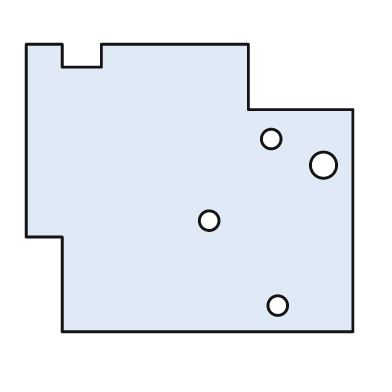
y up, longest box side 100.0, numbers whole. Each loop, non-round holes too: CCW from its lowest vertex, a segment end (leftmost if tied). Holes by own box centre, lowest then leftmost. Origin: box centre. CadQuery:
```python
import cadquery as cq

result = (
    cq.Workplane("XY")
    .moveTo(-39.0, -44.0)
    .lineTo(50.0, -44.0)
    .lineTo(50.0, 24.0)
    .lineTo(18.0, 24.0)
    .lineTo(18.0, 44.0)
    .lineTo(-27.0, 44.0)
    .lineTo(-27.0, 37.0)
    .lineTo(-39.0, 37.0)
    .lineTo(-39.0, 44.0)
    .lineTo(-50.0, 44.0)
    .lineTo(-50.0, -15.0)
    .lineTo(-39.0, -15.0)
    .close()
    .moveTo(27.0, -36.0)
    .circle(3.0)
    .moveTo(6.0, -10.0)
    .circle(3.0)
    .moveTo(41.0, 7.0)
    .circle(4.0)
    .moveTo(25.0, 15.0)
    .circle(3.0)
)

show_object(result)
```